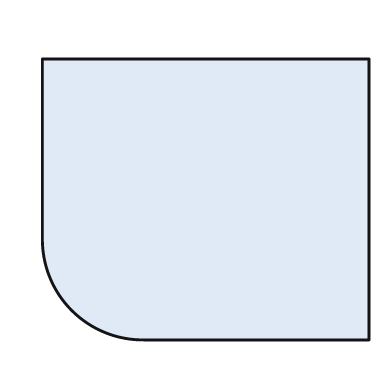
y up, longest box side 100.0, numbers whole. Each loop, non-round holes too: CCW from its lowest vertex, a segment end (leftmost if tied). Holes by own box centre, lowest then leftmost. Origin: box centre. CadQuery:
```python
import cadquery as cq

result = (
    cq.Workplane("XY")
    .moveTo(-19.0, -43.0)
    .lineTo(50.0, -43.0)
    .lineTo(50.0, 43.0)
    .lineTo(-50.0, 43.0)
    .lineTo(-50.0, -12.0)
    .threePointArc((-41.0, -34.0), (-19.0, -43.0))
    .close()
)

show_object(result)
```